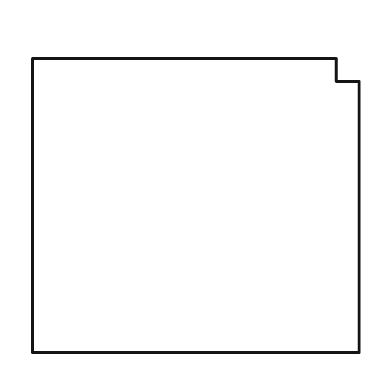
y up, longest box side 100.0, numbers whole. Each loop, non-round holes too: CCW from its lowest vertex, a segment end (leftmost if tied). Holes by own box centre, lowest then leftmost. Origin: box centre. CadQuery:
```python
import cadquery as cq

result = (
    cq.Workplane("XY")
    .moveTo(-50.0, -45.0)
    .lineTo(50.0, -45.0)
    .lineTo(50.0, 38.0)
    .lineTo(43.0, 38.0)
    .lineTo(43.0, 45.0)
    .lineTo(-50.0, 45.0)
    .close()
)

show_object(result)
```